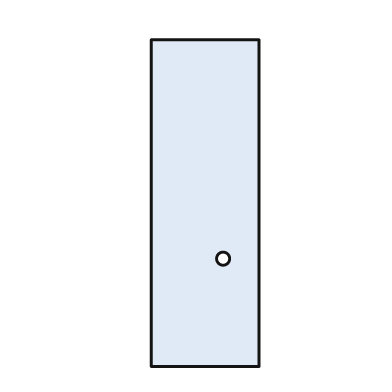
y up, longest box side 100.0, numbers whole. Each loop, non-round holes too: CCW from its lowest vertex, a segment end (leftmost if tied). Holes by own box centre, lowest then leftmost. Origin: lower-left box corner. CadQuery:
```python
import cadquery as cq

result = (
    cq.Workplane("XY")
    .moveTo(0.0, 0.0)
    .lineTo(33.0, 0.0)
    .lineTo(33.0, 100.0)
    .lineTo(0.0, 100.0)
    .close()
    .moveTo(22.0, 33.0)
    .circle(2.0)
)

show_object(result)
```